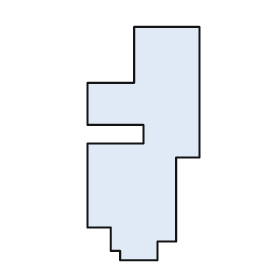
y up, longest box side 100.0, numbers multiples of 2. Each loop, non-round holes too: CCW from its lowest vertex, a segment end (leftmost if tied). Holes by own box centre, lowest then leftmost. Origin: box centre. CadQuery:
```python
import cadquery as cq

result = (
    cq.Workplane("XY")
    .moveTo(-10.0, -50.0)
    .lineTo(6.0, -50.0)
    .lineTo(6.0, -42.0)
    .lineTo(14.0, -42.0)
    .lineTo(14.0, -6.0)
    .lineTo(24.0, -6.0)
    .lineTo(24.0, 50.0)
    .lineTo(-4.0, 50.0)
    .lineTo(-4.0, 26.0)
    .lineTo(-24.0, 26.0)
    .lineTo(-24.0, 8.0)
    .lineTo(0.0, 8.0)
    .lineTo(0.0, 0.0)
    .lineTo(-24.0, 0.0)
    .lineTo(-24.0, -36.0)
    .lineTo(-14.0, -36.0)
    .lineTo(-14.0, -46.0)
    .lineTo(-10.0, -46.0)
    .close()
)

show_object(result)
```